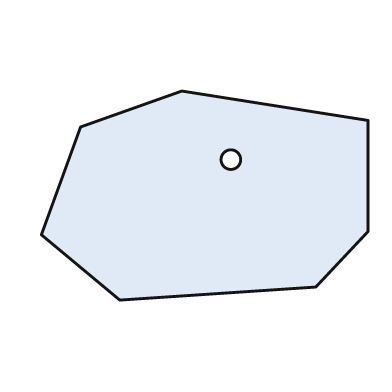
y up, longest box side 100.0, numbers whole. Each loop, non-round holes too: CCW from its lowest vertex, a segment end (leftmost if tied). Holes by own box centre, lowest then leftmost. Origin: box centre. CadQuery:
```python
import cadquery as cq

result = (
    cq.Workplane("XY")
    .moveTo(-26.0, -32.0)
    .lineTo(34.0, -28.0)
    .lineTo(50.0, -11.0)
    .lineTo(50.0, 23.0)
    .lineTo(-7.0, 32.0)
    .lineTo(-38.0, 21.0)
    .lineTo(-50.0, -12.0)
    .close()
    .moveTo(8.0, 11.0)
    .circle(3.0)
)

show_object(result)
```